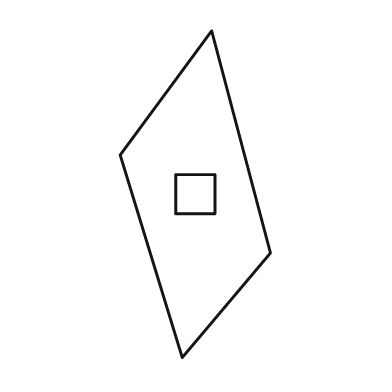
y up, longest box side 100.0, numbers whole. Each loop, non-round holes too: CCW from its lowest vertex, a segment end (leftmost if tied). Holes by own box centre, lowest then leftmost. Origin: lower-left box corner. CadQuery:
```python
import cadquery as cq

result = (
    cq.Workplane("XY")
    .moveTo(19.0, 0.0)
    .lineTo(46.0, 32.0)
    .lineTo(28.0, 100.0)
    .lineTo(0.0, 62.0)
    .close()
    .moveTo(17.0, 44.0)
    .lineTo(29.0, 44.0)
    .lineTo(29.0, 56.0)
    .lineTo(17.0, 56.0)
    .close()
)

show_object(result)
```